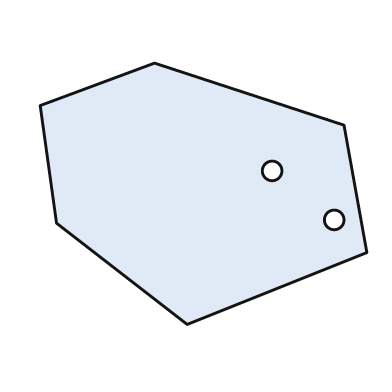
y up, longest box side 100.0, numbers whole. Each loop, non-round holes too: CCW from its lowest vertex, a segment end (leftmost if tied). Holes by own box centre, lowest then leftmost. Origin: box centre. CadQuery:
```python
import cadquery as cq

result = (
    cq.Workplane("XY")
    .moveTo(-5.0, -40.0)
    .lineTo(50.0, -18.0)
    .lineTo(43.0, 21.0)
    .lineTo(-15.0, 40.0)
    .lineTo(-50.0, 27.0)
    .lineTo(-45.0, -9.0)
    .close()
    .moveTo(40.0, -8.0)
    .circle(3.0)
    .moveTo(21.0, 7.0)
    .circle(3.0)
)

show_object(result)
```